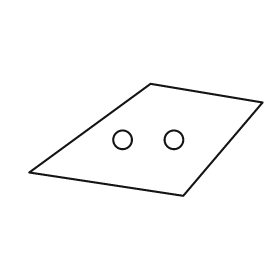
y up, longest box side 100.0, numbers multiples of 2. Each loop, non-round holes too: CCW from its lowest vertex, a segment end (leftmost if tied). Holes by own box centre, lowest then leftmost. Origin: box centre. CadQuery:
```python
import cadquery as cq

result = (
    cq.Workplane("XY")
    .moveTo(16.0, -24.0)
    .lineTo(50.0, 16.0)
    .lineTo(2.0, 24.0)
    .lineTo(-50.0, -14.0)
    .close()
    .moveTo(-10.0, 0.0)
    .circle(4.0)
    .moveTo(12.0, 0.0)
    .circle(4.0)
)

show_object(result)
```